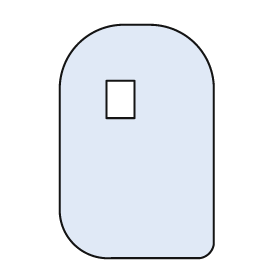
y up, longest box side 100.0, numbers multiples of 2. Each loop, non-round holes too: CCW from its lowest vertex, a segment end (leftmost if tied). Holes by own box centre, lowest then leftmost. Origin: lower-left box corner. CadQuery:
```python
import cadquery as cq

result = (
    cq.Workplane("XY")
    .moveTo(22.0, 0.0)
    .lineTo(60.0, 0.0)
    .threePointArc((64.0, 2.0), (66.0, 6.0))
    .lineTo(66.0, 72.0)
    .threePointArc((58.0, 92.0), (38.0, 100.0))
    .lineTo(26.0, 100.0)
    .threePointArc((8.0, 92.0), (0.0, 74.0))
    .lineTo(0.0, 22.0)
    .threePointArc((6.0, 6.0), (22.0, 0.0))
    .close()
    .moveTo(20.0, 60.0)
    .lineTo(32.0, 60.0)
    .lineTo(32.0, 76.0)
    .lineTo(20.0, 76.0)
    .close()
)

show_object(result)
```